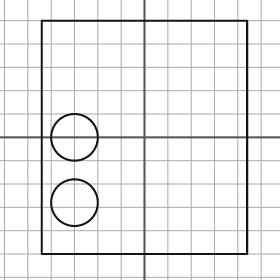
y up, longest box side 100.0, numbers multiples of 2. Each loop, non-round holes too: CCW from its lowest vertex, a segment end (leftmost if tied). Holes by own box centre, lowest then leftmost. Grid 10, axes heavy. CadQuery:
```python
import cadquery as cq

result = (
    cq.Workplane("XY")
    .moveTo(-44.0, -50.0)
    .lineTo(44.0, -50.0)
    .lineTo(44.0, 50.0)
    .lineTo(-44.0, 50.0)
    .close()
    .moveTo(-30.0, -28.0)
    .circle(10.0)
    .moveTo(-30.0, 0.0)
    .circle(10.0)
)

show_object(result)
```